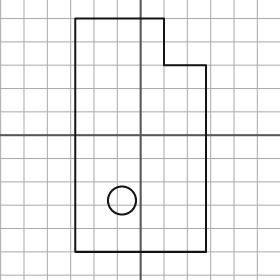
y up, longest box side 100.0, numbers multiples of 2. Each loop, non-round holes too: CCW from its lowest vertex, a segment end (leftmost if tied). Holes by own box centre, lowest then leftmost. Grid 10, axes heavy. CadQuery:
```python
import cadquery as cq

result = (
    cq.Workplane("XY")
    .moveTo(-28.0, -50.0)
    .lineTo(28.0, -50.0)
    .lineTo(28.0, 30.0)
    .lineTo(10.0, 30.0)
    .lineTo(10.0, 50.0)
    .lineTo(-28.0, 50.0)
    .close()
    .moveTo(-8.0, -28.0)
    .circle(6.0)
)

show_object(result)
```